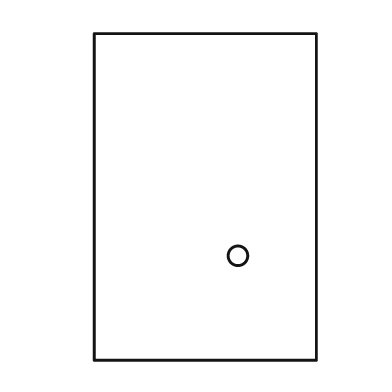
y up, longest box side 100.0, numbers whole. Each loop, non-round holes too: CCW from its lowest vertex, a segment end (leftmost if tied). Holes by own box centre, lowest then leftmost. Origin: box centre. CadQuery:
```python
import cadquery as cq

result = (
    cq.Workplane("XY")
    .moveTo(-34.0, -50.0)
    .lineTo(34.0, -50.0)
    .lineTo(34.0, 50.0)
    .lineTo(-34.0, 50.0)
    .close()
    .moveTo(10.0, -18.0)
    .circle(3.0)
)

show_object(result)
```